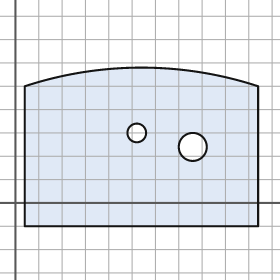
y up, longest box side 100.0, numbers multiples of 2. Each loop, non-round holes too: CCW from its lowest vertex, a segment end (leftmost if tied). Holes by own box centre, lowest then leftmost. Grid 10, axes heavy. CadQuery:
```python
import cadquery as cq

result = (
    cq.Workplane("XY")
    .moveTo(4.0, -10.0)
    .lineTo(104.0, -10.0)
    .lineTo(104.0, 50.0)
    .threePointArc((54.0, 58.0), (4.0, 50.0))
    .close()
    .moveTo(76.0, 24.0)
    .circle(6.0)
    .moveTo(52.0, 30.0)
    .circle(4.0)
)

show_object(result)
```